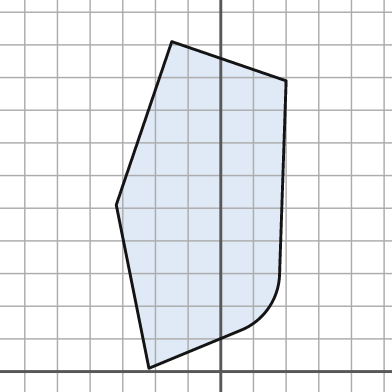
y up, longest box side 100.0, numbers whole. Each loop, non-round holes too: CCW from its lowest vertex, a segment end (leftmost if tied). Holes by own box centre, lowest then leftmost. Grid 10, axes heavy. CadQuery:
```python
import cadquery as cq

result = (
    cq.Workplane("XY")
    .moveTo(-22.0, 1.0)
    .lineTo(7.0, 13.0)
    .threePointArc((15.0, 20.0), (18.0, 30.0))
    .lineTo(20.0, 89.0)
    .lineTo(-15.0, 101.0)
    .lineTo(-32.0, 51.0)
    .close()
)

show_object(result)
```